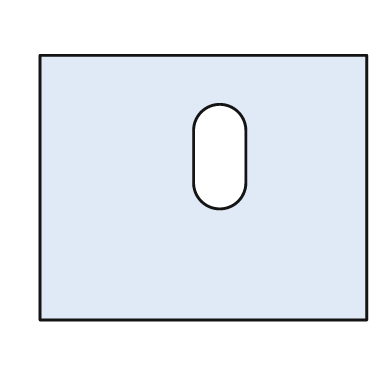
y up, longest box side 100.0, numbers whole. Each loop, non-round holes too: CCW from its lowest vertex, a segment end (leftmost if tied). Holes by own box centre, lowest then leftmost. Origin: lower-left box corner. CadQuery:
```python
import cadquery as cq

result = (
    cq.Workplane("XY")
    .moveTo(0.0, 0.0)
    .lineTo(100.0, 0.0)
    .lineTo(100.0, 81.0)
    .lineTo(0.0, 81.0)
    .close()
    .moveTo(47.0, 42.0)
    .threePointArc((55.0, 34.0), (63.0, 42.0))
    .lineTo(63.0, 58.0)
    .threePointArc((55.0, 66.0), (47.0, 58.0))
    .close()
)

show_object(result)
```